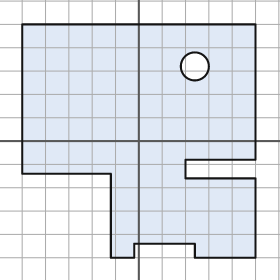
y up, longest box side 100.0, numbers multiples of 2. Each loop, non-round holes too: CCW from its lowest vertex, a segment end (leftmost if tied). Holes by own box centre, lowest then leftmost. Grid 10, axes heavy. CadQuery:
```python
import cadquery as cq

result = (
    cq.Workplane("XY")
    .moveTo(-12.0, -50.0)
    .lineTo(-2.0, -50.0)
    .lineTo(-2.0, -44.0)
    .lineTo(24.0, -44.0)
    .lineTo(24.0, -50.0)
    .lineTo(50.0, -50.0)
    .lineTo(50.0, -16.0)
    .lineTo(20.0, -16.0)
    .lineTo(20.0, -8.0)
    .lineTo(50.0, -8.0)
    .lineTo(50.0, 50.0)
    .lineTo(-50.0, 50.0)
    .lineTo(-50.0, -14.0)
    .lineTo(-12.0, -14.0)
    .close()
    .moveTo(24.0, 32.0)
    .circle(6.0)
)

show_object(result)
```